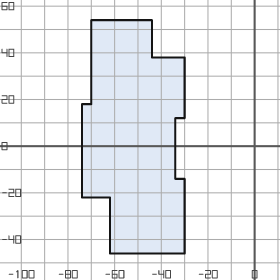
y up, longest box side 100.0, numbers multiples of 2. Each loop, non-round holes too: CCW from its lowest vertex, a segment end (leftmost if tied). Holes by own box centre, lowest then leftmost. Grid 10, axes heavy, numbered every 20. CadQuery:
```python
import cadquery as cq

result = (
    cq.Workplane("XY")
    .moveTo(-62.0, -46.0)
    .lineTo(-30.0, -46.0)
    .lineTo(-30.0, -14.0)
    .lineTo(-34.0, -14.0)
    .lineTo(-34.0, 12.0)
    .lineTo(-30.0, 12.0)
    .lineTo(-30.0, 38.0)
    .lineTo(-44.0, 38.0)
    .lineTo(-44.0, 54.0)
    .lineTo(-70.0, 54.0)
    .lineTo(-70.0, 18.0)
    .lineTo(-74.0, 18.0)
    .lineTo(-74.0, -22.0)
    .lineTo(-62.0, -22.0)
    .close()
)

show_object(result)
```